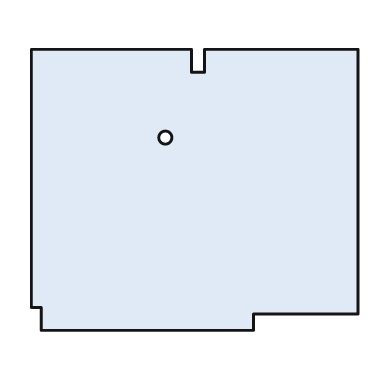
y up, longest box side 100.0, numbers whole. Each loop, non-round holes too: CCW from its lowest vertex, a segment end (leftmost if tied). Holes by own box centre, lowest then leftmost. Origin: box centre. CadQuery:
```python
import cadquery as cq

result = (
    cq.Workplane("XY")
    .moveTo(-47.0, -43.0)
    .lineTo(18.0, -43.0)
    .lineTo(18.0, -38.0)
    .lineTo(50.0, -38.0)
    .lineTo(50.0, 43.0)
    .lineTo(3.0, 43.0)
    .lineTo(3.0, 36.0)
    .lineTo(-1.0, 36.0)
    .lineTo(-1.0, 43.0)
    .lineTo(-50.0, 43.0)
    .lineTo(-50.0, -36.0)
    .lineTo(-47.0, -36.0)
    .close()
    .moveTo(-9.0, 16.0)
    .circle(2.0)
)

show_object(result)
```